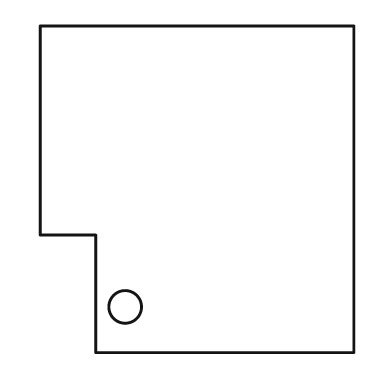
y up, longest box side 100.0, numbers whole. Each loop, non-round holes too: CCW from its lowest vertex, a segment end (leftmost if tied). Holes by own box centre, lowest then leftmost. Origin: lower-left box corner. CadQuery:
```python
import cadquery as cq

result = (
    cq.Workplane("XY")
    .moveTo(17.0, 0.0)
    .lineTo(96.0, 0.0)
    .lineTo(96.0, 100.0)
    .lineTo(0.0, 100.0)
    .lineTo(0.0, 36.0)
    .lineTo(17.0, 36.0)
    .close()
    .moveTo(26.0, 14.0)
    .circle(5.0)
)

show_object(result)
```